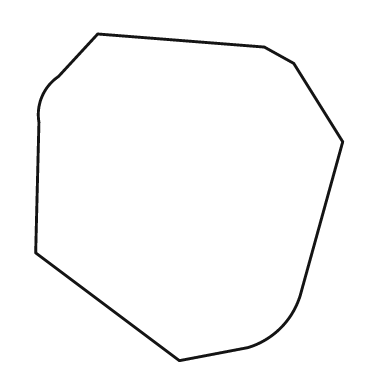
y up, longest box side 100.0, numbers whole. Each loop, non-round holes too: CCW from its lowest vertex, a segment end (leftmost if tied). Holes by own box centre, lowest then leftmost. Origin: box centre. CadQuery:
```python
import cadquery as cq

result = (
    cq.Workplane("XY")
    .moveTo(-3.0, -50.0)
    .lineTo(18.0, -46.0)
    .threePointArc((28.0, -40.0), (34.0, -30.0))
    .lineTo(47.0, 17.0)
    .lineTo(32.0, 41.0)
    .lineTo(23.0, 46.0)
    .lineTo(-28.0, 50.0)
    .lineTo(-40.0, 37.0)
    .threePointArc((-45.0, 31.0), (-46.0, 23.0))
    .lineTo(-47.0, -17.0)
    .close()
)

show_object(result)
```